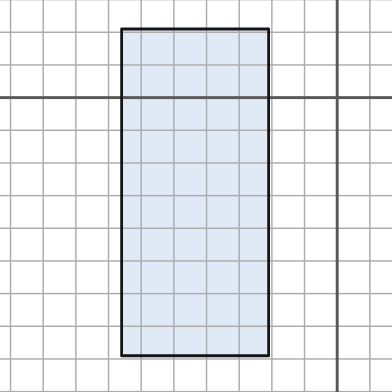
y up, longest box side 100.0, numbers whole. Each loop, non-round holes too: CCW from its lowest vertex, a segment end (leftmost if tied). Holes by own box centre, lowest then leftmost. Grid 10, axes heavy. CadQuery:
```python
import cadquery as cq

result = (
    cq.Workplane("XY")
    .moveTo(-66.0, -79.0)
    .lineTo(-21.0, -79.0)
    .lineTo(-21.0, 21.0)
    .lineTo(-66.0, 21.0)
    .close()
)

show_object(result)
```